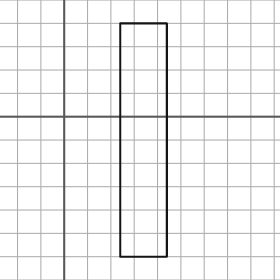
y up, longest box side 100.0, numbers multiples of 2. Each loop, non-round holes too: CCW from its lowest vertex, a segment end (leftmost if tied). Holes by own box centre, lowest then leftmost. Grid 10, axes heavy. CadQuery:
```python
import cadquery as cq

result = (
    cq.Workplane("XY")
    .moveTo(24.0, -60.0)
    .lineTo(44.0, -60.0)
    .lineTo(44.0, 40.0)
    .lineTo(24.0, 40.0)
    .close()
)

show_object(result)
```